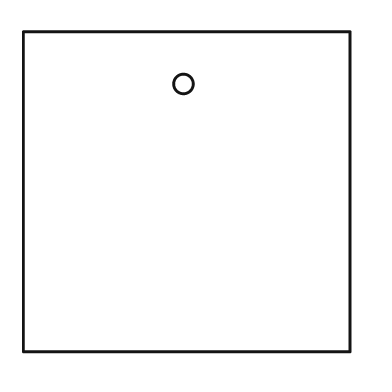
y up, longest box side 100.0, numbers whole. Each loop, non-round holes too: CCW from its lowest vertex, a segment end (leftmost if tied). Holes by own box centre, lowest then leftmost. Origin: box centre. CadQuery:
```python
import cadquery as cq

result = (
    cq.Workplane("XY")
    .moveTo(-50.0, -49.0)
    .lineTo(50.0, -49.0)
    .lineTo(50.0, 49.0)
    .lineTo(-50.0, 49.0)
    .close()
    .moveTo(-1.0, 33.0)
    .circle(3.0)
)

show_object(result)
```